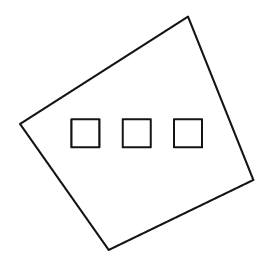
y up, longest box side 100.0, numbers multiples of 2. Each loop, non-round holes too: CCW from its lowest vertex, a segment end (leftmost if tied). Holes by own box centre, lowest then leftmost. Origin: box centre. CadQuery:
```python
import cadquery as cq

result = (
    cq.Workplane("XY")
    .moveTo(-12.0, -50.0)
    .lineTo(50.0, -20.0)
    .lineTo(22.0, 50.0)
    .lineTo(-50.0, 4.0)
    .close()
    .moveTo(-28.0, -6.0)
    .lineTo(-16.0, -6.0)
    .lineTo(-16.0, 6.0)
    .lineTo(-28.0, 6.0)
    .close()
    .moveTo(-6.0, -6.0)
    .lineTo(6.0, -6.0)
    .lineTo(6.0, 6.0)
    .lineTo(-6.0, 6.0)
    .close()
    .moveTo(16.0, -6.0)
    .lineTo(28.0, -6.0)
    .lineTo(28.0, 6.0)
    .lineTo(16.0, 6.0)
    .close()
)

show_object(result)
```